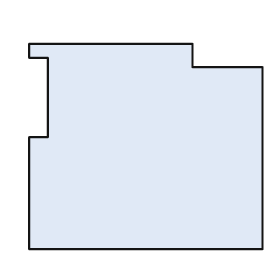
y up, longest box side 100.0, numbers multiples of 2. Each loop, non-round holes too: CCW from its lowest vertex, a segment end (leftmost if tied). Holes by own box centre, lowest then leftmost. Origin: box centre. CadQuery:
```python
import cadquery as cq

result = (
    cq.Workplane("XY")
    .moveTo(-50.0, -44.0)
    .lineTo(50.0, -44.0)
    .lineTo(50.0, 34.0)
    .lineTo(20.0, 34.0)
    .lineTo(20.0, 44.0)
    .lineTo(-50.0, 44.0)
    .lineTo(-50.0, 38.0)
    .lineTo(-42.0, 38.0)
    .lineTo(-42.0, 4.0)
    .lineTo(-50.0, 4.0)
    .close()
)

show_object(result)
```